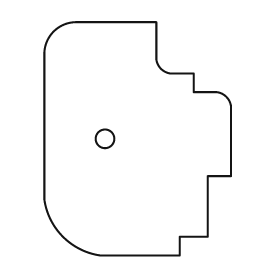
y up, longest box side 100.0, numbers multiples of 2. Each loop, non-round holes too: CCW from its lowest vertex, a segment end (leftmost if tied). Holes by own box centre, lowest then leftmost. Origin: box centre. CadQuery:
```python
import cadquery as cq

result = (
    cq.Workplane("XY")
    .moveTo(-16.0, -50.0)
    .lineTo(18.0, -50.0)
    .lineTo(18.0, -42.0)
    .lineTo(30.0, -42.0)
    .lineTo(30.0, -16.0)
    .lineTo(40.0, -16.0)
    .lineTo(40.0, 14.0)
    .threePointArc((38.0, 18.0), (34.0, 20.0))
    .lineTo(24.0, 20.0)
    .lineTo(24.0, 28.0)
    .lineTo(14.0, 28.0)
    .threePointArc((10.0, 30.0), (8.0, 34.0))
    .lineTo(8.0, 50.0)
    .lineTo(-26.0, 50.0)
    .threePointArc((-36.0, 46.0), (-40.0, 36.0))
    .lineTo(-40.0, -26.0)
    .threePointArc((-32.0, -42.0), (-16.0, -50.0))
    .close()
    .moveTo(-14.0, 0.0)
    .circle(4.0)
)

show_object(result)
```